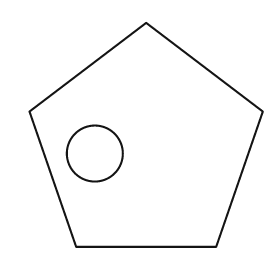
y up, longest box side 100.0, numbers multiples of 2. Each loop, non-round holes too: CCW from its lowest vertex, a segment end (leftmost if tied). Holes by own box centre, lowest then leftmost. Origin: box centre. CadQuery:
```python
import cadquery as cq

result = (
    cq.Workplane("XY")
    .moveTo(-30.0, -48.0)
    .lineTo(30.0, -48.0)
    .lineTo(50.0, 10.0)
    .lineTo(0.0, 48.0)
    .lineTo(-50.0, 10.0)
    .close()
    .moveTo(-22.0, -8.0)
    .circle(12.0)
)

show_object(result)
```